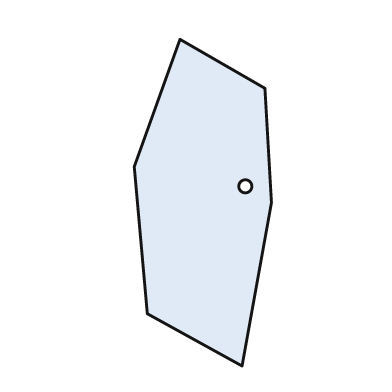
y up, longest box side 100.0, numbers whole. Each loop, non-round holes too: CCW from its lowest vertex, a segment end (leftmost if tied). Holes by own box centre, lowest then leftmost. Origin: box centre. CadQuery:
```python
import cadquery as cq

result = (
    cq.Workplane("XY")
    .moveTo(12.0, -50.0)
    .lineTo(21.0, 0.0)
    .lineTo(19.0, 35.0)
    .lineTo(-7.0, 50.0)
    .lineTo(-21.0, 11.0)
    .lineTo(-17.0, -34.0)
    .close()
    .moveTo(13.0, 5.0)
    .circle(2.0)
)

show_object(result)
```